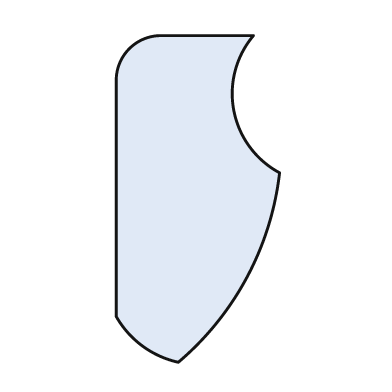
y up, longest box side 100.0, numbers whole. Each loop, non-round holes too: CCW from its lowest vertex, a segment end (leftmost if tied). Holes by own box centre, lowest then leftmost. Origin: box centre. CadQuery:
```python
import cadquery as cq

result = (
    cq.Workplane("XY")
    .moveTo(-6.0, -50.0)
    .threePointArc((15.0, -24.0), (25.0, 8.0))
    .threePointArc((11.0, 27.0), (17.0, 50.0))
    .lineTo(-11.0, 50.0)
    .threePointArc((-21.0, 46.0), (-25.0, 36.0))
    .lineTo(-25.0, -36.0)
    .threePointArc((-17.0, -45.0), (-6.0, -50.0))
    .close()
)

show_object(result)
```